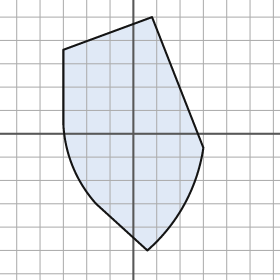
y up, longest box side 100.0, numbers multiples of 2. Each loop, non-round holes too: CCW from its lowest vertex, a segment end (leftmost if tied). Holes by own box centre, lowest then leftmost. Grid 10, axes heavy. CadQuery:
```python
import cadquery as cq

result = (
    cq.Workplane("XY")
    .moveTo(6.0, -50.0)
    .threePointArc((22.0, -30.0), (30.0, -6.0))
    .lineTo(8.0, 50.0)
    .lineTo(-30.0, 36.0)
    .lineTo(-30.0, 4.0)
    .threePointArc((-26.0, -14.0), (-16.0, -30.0))
    .close()
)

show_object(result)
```